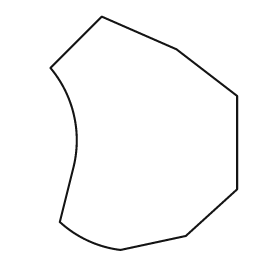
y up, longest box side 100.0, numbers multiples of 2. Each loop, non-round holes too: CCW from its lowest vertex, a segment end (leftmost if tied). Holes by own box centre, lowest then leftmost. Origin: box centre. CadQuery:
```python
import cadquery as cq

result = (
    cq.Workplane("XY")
    .moveTo(-10.0, -50.0)
    .lineTo(18.0, -44.0)
    .lineTo(40.0, -24.0)
    .lineTo(40.0, 16.0)
    .lineTo(14.0, 36.0)
    .lineTo(-18.0, 50.0)
    .lineTo(-40.0, 28.0)
    .threePointArc((-30.0, 8.0), (-30.0, -14.0))
    .lineTo(-36.0, -38.0)
    .threePointArc((-24.0, -46.0), (-10.0, -50.0))
    .close()
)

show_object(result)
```